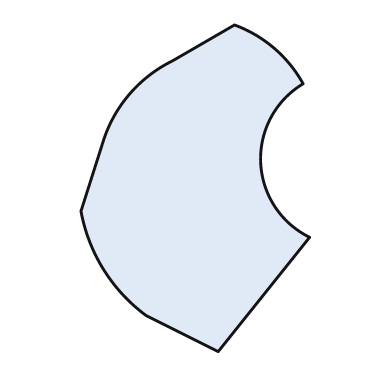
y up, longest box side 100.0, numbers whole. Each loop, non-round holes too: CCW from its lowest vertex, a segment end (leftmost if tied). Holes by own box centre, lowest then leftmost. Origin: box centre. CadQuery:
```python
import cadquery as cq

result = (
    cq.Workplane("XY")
    .moveTo(7.0, -50.0)
    .lineTo(35.0, -15.0)
    .threePointArc((20.0, 8.0), (33.0, 32.0))
    .threePointArc((24.0, 43.0), (12.0, 50.0))
    .lineTo(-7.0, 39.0)
    .threePointArc((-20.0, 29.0), (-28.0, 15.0))
    .lineTo(-35.0, -7.0)
    .threePointArc((-28.0, -25.0), (-15.0, -39.0))
    .close()
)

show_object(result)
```